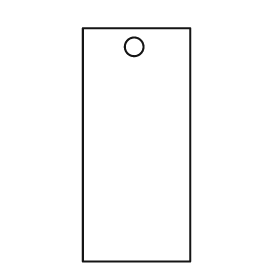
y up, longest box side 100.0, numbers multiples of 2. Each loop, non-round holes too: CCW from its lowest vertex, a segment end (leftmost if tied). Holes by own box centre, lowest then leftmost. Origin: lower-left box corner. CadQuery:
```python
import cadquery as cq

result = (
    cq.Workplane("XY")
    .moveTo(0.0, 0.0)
    .lineTo(46.0, 0.0)
    .lineTo(46.0, 100.0)
    .lineTo(0.0, 100.0)
    .close()
    .moveTo(22.0, 92.0)
    .circle(4.0)
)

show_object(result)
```